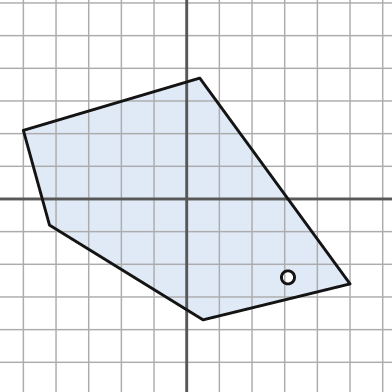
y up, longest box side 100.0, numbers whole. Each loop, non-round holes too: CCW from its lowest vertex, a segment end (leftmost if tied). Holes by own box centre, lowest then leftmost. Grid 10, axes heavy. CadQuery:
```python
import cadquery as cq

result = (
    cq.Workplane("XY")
    .moveTo(5.0, -37.0)
    .lineTo(50.0, -26.0)
    .lineTo(4.0, 37.0)
    .lineTo(-50.0, 21.0)
    .lineTo(-42.0, -8.0)
    .close()
    .moveTo(31.0, -24.0)
    .circle(2.0)
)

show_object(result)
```